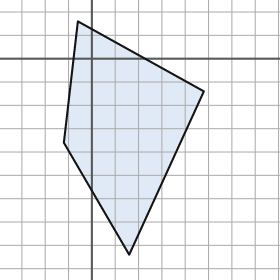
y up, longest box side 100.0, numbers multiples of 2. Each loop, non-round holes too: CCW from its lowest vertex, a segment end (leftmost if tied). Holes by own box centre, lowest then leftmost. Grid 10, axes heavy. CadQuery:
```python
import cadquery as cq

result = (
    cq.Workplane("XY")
    .moveTo(16.0, -84.0)
    .lineTo(48.0, -14.0)
    .lineTo(-6.0, 16.0)
    .lineTo(-12.0, -36.0)
    .close()
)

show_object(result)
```